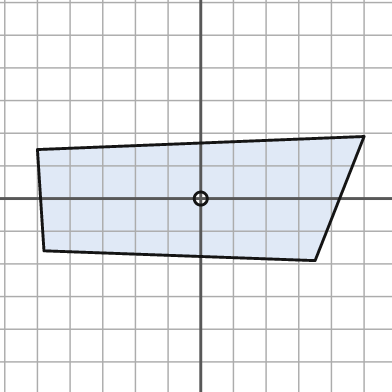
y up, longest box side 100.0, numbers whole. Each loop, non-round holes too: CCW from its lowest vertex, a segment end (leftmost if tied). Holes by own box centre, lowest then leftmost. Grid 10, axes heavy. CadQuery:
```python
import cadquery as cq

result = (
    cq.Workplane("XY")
    .moveTo(35.0, -19.0)
    .lineTo(50.0, 19.0)
    .lineTo(-50.0, 15.0)
    .lineTo(-48.0, -16.0)
    .close()
    .moveTo(0.0, 0.0)
    .circle(2.0)
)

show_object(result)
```